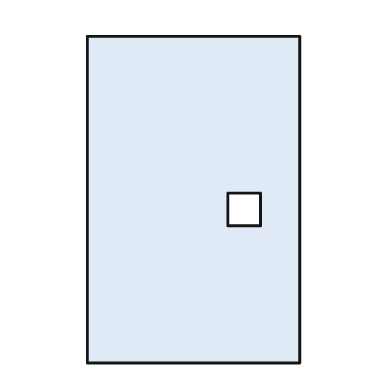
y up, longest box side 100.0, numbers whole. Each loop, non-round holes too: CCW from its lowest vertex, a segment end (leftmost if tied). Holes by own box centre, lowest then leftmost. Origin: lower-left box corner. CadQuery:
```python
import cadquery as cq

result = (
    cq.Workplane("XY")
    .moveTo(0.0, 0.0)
    .lineTo(65.0, 0.0)
    .lineTo(65.0, 100.0)
    .lineTo(0.0, 100.0)
    .close()
    .moveTo(43.0, 42.0)
    .lineTo(53.0, 42.0)
    .lineTo(53.0, 52.0)
    .lineTo(43.0, 52.0)
    .close()
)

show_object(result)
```